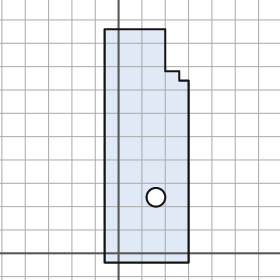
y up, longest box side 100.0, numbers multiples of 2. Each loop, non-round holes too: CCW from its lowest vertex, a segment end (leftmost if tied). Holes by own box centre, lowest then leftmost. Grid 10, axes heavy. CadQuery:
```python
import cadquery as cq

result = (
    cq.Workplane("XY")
    .moveTo(-6.0, -4.0)
    .lineTo(30.0, -4.0)
    .lineTo(30.0, 74.0)
    .lineTo(26.0, 74.0)
    .lineTo(26.0, 78.0)
    .lineTo(20.0, 78.0)
    .lineTo(20.0, 96.0)
    .lineTo(-6.0, 96.0)
    .close()
    .moveTo(16.0, 24.0)
    .circle(4.0)
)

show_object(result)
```